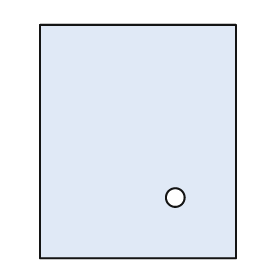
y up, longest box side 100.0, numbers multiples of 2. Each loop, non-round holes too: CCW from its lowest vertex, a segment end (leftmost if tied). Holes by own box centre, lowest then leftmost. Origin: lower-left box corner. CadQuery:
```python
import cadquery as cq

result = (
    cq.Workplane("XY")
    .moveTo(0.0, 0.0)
    .lineTo(84.0, 0.0)
    .lineTo(84.0, 100.0)
    .lineTo(0.0, 100.0)
    .close()
    .moveTo(58.0, 26.0)
    .circle(4.0)
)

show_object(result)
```